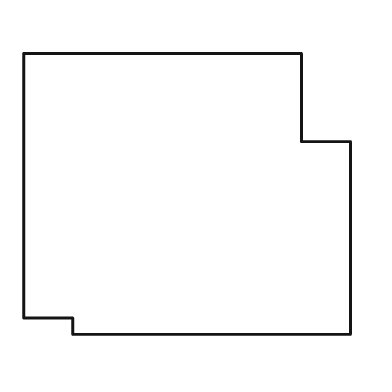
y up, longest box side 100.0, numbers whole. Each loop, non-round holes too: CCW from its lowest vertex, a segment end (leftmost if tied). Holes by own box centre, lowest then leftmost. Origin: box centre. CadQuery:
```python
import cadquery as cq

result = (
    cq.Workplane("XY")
    .moveTo(-35.0, -43.0)
    .lineTo(50.0, -43.0)
    .lineTo(50.0, 16.0)
    .lineTo(35.0, 16.0)
    .lineTo(35.0, 43.0)
    .lineTo(-50.0, 43.0)
    .lineTo(-50.0, -38.0)
    .lineTo(-35.0, -38.0)
    .close()
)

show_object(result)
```